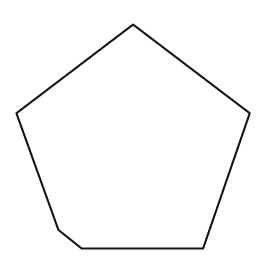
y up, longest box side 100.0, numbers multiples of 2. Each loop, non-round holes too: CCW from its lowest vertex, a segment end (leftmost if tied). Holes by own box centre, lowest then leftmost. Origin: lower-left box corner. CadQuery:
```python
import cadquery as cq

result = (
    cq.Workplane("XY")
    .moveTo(28.0, 0.0)
    .lineTo(80.0, 0.0)
    .lineTo(100.0, 58.0)
    .lineTo(50.0, 96.0)
    .lineTo(0.0, 58.0)
    .lineTo(18.0, 8.0)
    .close()
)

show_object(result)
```